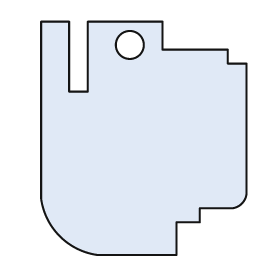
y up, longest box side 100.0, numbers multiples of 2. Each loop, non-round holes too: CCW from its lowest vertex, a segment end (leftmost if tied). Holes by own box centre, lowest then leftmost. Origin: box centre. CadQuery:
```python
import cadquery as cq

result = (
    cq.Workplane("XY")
    .moveTo(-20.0, -50.0)
    .lineTo(14.0, -50.0)
    .lineTo(14.0, -36.0)
    .lineTo(24.0, -36.0)
    .lineTo(24.0, -30.0)
    .lineTo(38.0, -30.0)
    .threePointArc((42.0, -28.0), (44.0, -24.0))
    .lineTo(44.0, 32.0)
    .lineTo(36.0, 32.0)
    .lineTo(36.0, 38.0)
    .lineTo(8.0, 38.0)
    .lineTo(8.0, 50.0)
    .lineTo(-24.0, 50.0)
    .lineTo(-24.0, 20.0)
    .lineTo(-32.0, 20.0)
    .lineTo(-32.0, 50.0)
    .lineTo(-44.0, 50.0)
    .lineTo(-44.0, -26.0)
    .threePointArc((-36.0, -42.0), (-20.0, -50.0))
    .close()
    .moveTo(-6.0, 40.0)
    .circle(6.0)
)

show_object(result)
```